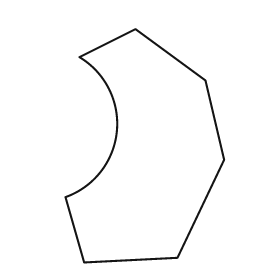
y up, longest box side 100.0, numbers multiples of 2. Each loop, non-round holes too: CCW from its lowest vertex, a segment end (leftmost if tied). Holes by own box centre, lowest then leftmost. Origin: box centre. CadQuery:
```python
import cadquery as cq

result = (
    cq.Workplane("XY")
    .moveTo(-26.0, -50.0)
    .lineTo(14.0, -48.0)
    .lineTo(34.0, -6.0)
    .lineTo(26.0, 28.0)
    .lineTo(-4.0, 50.0)
    .lineTo(-28.0, 38.0)
    .threePointArc((-12.0, 6.0), (-34.0, -22.0))
    .close()
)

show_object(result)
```